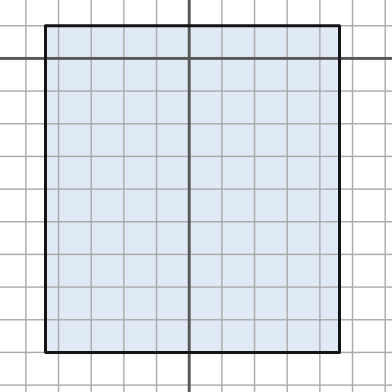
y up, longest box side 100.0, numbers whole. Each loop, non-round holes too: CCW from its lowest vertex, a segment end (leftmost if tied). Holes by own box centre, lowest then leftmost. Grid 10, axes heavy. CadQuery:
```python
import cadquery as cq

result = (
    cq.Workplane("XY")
    .moveTo(-44.0, -90.0)
    .lineTo(46.0, -90.0)
    .lineTo(46.0, 10.0)
    .lineTo(-44.0, 10.0)
    .close()
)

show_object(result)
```